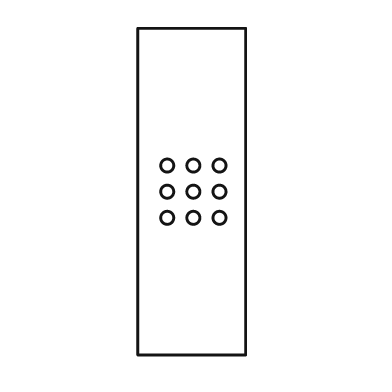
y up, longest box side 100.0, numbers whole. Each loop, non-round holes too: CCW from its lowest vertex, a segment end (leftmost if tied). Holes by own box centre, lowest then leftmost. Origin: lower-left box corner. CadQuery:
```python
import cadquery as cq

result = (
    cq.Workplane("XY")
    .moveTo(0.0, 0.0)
    .lineTo(33.0, 0.0)
    .lineTo(33.0, 100.0)
    .lineTo(0.0, 100.0)
    .close()
    .moveTo(9.0, 42.0)
    .circle(2.0)
    .moveTo(17.0, 42.0)
    .circle(2.0)
    .moveTo(25.0, 42.0)
    .circle(2.0)
    .moveTo(9.0, 50.0)
    .circle(2.0)
    .moveTo(17.0, 50.0)
    .circle(2.0)
    .moveTo(25.0, 50.0)
    .circle(2.0)
    .moveTo(9.0, 58.0)
    .circle(2.0)
    .moveTo(17.0, 58.0)
    .circle(2.0)
    .moveTo(25.0, 58.0)
    .circle(2.0)
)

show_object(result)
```